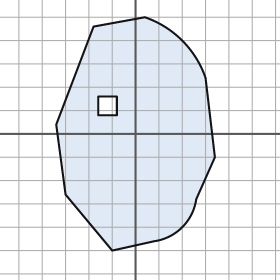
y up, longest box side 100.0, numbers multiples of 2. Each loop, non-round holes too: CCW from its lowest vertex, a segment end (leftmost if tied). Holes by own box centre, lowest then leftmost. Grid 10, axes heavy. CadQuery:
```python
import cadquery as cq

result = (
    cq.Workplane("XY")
    .moveTo(-10.0, -50.0)
    .lineTo(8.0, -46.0)
    .threePointArc((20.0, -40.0), (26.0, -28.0))
    .lineTo(34.0, -10.0)
    .lineTo(30.0, 24.0)
    .threePointArc((20.0, 40.0), (4.0, 50.0))
    .lineTo(-18.0, 46.0)
    .lineTo(-34.0, 4.0)
    .lineTo(-30.0, -26.0)
    .close()
    .moveTo(-16.0, 8.0)
    .lineTo(-8.0, 8.0)
    .lineTo(-8.0, 16.0)
    .lineTo(-16.0, 16.0)
    .close()
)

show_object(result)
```